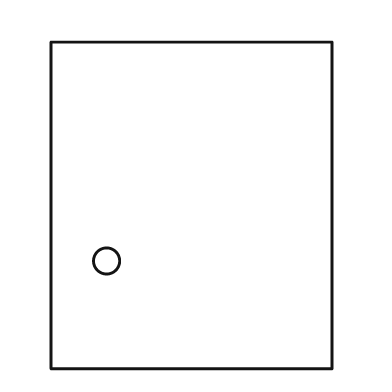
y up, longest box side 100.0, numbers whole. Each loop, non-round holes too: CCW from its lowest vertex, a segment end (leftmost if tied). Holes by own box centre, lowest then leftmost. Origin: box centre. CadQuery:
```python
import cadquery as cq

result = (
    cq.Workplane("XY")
    .moveTo(-43.0, -50.0)
    .lineTo(43.0, -50.0)
    .lineTo(43.0, 50.0)
    .lineTo(-43.0, 50.0)
    .close()
    .moveTo(-26.0, -17.0)
    .circle(4.0)
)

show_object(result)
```